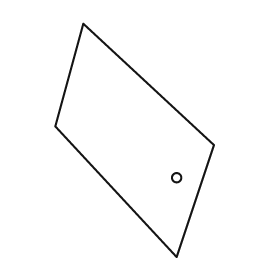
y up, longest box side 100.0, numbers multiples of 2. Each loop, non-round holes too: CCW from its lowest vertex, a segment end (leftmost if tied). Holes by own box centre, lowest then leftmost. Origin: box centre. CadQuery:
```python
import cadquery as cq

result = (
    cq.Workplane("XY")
    .moveTo(18.0, -50.0)
    .lineTo(34.0, -2.0)
    .lineTo(-22.0, 50.0)
    .lineTo(-34.0, 6.0)
    .close()
    .moveTo(18.0, -16.0)
    .circle(2.0)
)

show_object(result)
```